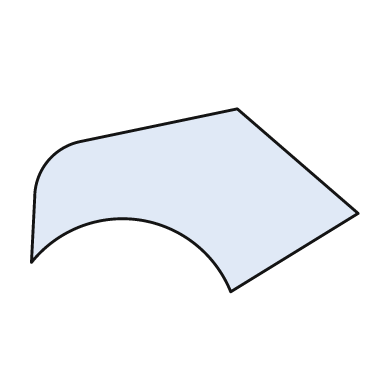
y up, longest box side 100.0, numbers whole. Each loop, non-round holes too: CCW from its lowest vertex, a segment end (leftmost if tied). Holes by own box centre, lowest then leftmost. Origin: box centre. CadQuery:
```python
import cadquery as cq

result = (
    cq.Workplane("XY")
    .moveTo(11.0, -28.0)
    .lineTo(50.0, -4.0)
    .lineTo(13.0, 28.0)
    .lineTo(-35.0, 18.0)
    .threePointArc((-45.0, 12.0), (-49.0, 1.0))
    .lineTo(-50.0, -19.0)
    .threePointArc((-17.0, -6.0), (11.0, -28.0))
    .close()
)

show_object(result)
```